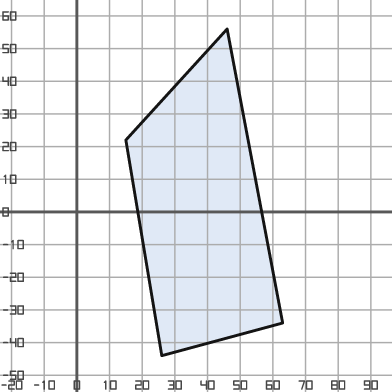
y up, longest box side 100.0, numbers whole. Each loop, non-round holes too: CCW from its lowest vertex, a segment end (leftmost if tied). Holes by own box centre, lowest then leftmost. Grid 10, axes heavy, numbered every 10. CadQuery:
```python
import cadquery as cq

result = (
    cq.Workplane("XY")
    .moveTo(26.0, -44.0)
    .lineTo(63.0, -34.0)
    .lineTo(46.0, 56.0)
    .lineTo(15.0, 22.0)
    .close()
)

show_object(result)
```